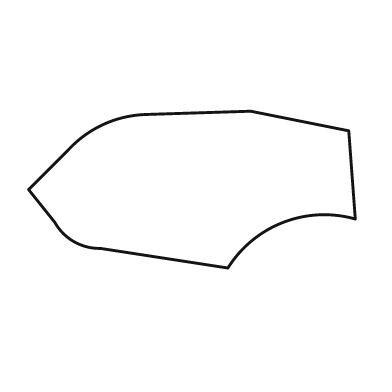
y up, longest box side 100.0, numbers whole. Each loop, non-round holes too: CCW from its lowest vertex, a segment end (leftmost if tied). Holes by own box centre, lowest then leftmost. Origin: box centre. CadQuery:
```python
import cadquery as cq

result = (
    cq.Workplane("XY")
    .moveTo(11.0, -24.0)
    .threePointArc((28.0, -10.0), (50.0, -9.0))
    .lineTo(48.0, 18.0)
    .lineTo(18.0, 24.0)
    .lineTo(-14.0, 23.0)
    .threePointArc((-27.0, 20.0), (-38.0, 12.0))
    .lineTo(-50.0, 0.0)
    .lineTo(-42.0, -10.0)
    .threePointArc((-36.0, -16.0), (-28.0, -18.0))
    .close()
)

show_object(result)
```